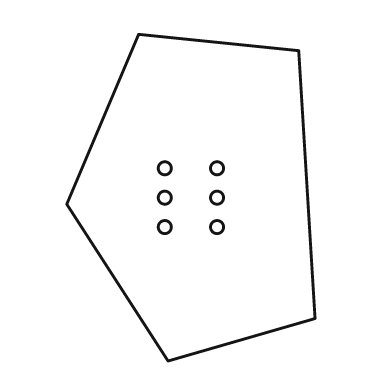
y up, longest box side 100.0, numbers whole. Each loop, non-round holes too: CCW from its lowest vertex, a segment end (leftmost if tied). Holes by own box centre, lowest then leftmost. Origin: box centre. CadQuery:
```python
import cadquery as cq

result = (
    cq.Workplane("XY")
    .moveTo(-7.0, -50.0)
    .lineTo(38.0, -37.0)
    .lineTo(33.0, 45.0)
    .lineTo(-16.0, 50.0)
    .lineTo(-38.0, -2.0)
    .close()
    .moveTo(-8.0, -9.0)
    .circle(2.0)
    .moveTo(8.0, -9.0)
    .circle(2.0)
    .moveTo(-8.0, 0.0)
    .circle(2.0)
    .moveTo(8.0, 0.0)
    .circle(2.0)
    .moveTo(-8.0, 9.0)
    .circle(2.0)
    .moveTo(8.0, 9.0)
    .circle(2.0)
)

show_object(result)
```